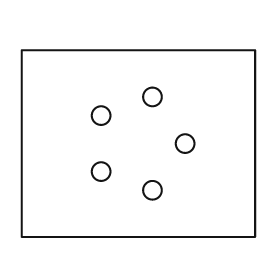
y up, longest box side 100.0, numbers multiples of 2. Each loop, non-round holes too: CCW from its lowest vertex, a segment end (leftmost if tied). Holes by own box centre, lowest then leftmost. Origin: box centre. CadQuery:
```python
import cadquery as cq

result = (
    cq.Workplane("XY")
    .moveTo(-50.0, -40.0)
    .lineTo(50.0, -40.0)
    .lineTo(50.0, 40.0)
    .lineTo(-50.0, 40.0)
    .close()
    .moveTo(6.0, -20.0)
    .circle(4.0)
    .moveTo(-16.0, -12.0)
    .circle(4.0)
    .moveTo(20.0, 0.0)
    .circle(4.0)
    .moveTo(-16.0, 12.0)
    .circle(4.0)
    .moveTo(6.0, 20.0)
    .circle(4.0)
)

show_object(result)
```